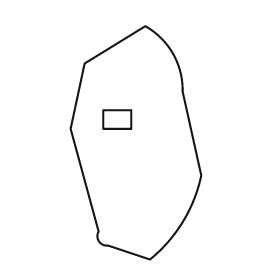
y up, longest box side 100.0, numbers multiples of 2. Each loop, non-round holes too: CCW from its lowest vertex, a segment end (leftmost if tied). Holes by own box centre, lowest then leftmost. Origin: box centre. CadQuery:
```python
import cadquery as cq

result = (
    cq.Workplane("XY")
    .moveTo(6.0, -50.0)
    .threePointArc((20.0, -34.0), (28.0, -14.0))
    .lineTo(20.0, 22.0)
    .threePointArc((16.0, 38.0), (4.0, 50.0))
    .lineTo(-22.0, 34.0)
    .lineTo(-28.0, 6.0)
    .lineTo(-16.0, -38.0)
    .threePointArc((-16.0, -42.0), (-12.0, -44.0))
    .close()
    .moveTo(-14.0, 6.0)
    .lineTo(-2.0, 6.0)
    .lineTo(-2.0, 14.0)
    .lineTo(-14.0, 14.0)
    .close()
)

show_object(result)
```